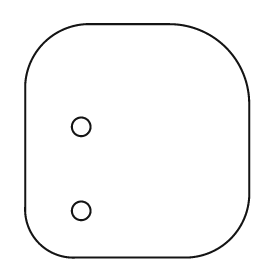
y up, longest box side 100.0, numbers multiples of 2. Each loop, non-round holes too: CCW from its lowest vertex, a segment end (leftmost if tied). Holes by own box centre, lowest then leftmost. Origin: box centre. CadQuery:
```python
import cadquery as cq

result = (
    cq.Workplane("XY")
    .moveTo(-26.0, -50.0)
    .lineTo(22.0, -50.0)
    .threePointArc((40.0, -42.0), (48.0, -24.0))
    .lineTo(48.0, 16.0)
    .threePointArc((38.0, 40.0), (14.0, 50.0))
    .lineTo(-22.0, 50.0)
    .threePointArc((-40.0, 42.0), (-48.0, 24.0))
    .lineTo(-48.0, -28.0)
    .threePointArc((-42.0, -44.0), (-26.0, -50.0))
    .close()
    .moveTo(-24.0, -30.0)
    .circle(4.0)
    .moveTo(-24.0, 6.0)
    .circle(4.0)
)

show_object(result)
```